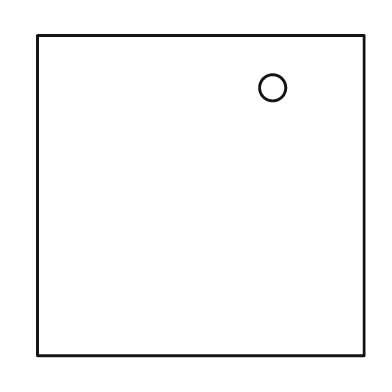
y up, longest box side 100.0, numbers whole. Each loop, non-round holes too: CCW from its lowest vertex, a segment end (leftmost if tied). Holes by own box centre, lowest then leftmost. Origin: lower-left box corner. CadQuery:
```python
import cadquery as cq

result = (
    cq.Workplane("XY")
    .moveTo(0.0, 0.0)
    .lineTo(100.0, 0.0)
    .lineTo(100.0, 98.0)
    .lineTo(0.0, 98.0)
    .close()
    .moveTo(72.0, 82.0)
    .circle(4.0)
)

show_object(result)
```